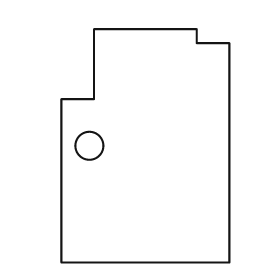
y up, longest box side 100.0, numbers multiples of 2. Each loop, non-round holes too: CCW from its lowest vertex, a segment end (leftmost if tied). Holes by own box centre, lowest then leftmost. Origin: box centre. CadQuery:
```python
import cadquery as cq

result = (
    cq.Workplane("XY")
    .moveTo(-36.0, -50.0)
    .lineTo(36.0, -50.0)
    .lineTo(36.0, 44.0)
    .lineTo(22.0, 44.0)
    .lineTo(22.0, 50.0)
    .lineTo(-22.0, 50.0)
    .lineTo(-22.0, 20.0)
    .lineTo(-36.0, 20.0)
    .close()
    .moveTo(-24.0, 0.0)
    .circle(6.0)
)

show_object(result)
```